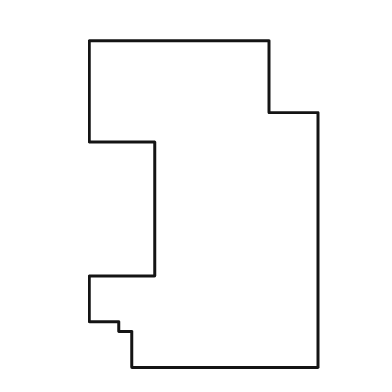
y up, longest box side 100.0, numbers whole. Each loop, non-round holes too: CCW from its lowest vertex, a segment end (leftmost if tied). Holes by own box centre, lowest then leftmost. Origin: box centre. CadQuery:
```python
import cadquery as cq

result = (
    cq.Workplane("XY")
    .moveTo(-22.0, -50.0)
    .lineTo(35.0, -50.0)
    .lineTo(35.0, 28.0)
    .lineTo(20.0, 28.0)
    .lineTo(20.0, 50.0)
    .lineTo(-35.0, 50.0)
    .lineTo(-35.0, 19.0)
    .lineTo(-15.0, 19.0)
    .lineTo(-15.0, -22.0)
    .lineTo(-35.0, -22.0)
    .lineTo(-35.0, -36.0)
    .lineTo(-26.0, -36.0)
    .lineTo(-26.0, -39.0)
    .lineTo(-22.0, -39.0)
    .close()
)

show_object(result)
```